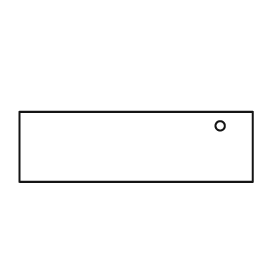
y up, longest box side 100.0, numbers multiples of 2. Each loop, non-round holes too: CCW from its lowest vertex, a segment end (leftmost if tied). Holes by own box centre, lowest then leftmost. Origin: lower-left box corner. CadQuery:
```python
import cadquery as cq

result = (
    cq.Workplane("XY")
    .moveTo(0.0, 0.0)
    .lineTo(100.0, 0.0)
    .lineTo(100.0, 30.0)
    .lineTo(0.0, 30.0)
    .close()
    .moveTo(86.0, 24.0)
    .circle(2.0)
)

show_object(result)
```